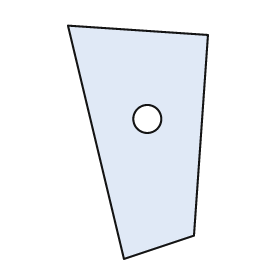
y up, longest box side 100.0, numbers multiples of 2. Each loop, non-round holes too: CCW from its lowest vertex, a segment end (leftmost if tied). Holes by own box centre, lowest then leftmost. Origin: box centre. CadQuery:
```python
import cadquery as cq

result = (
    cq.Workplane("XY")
    .moveTo(-6.0, -50.0)
    .lineTo(24.0, -40.0)
    .lineTo(30.0, 46.0)
    .lineTo(-30.0, 50.0)
    .close()
    .moveTo(4.0, 10.0)
    .circle(6.0)
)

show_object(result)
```